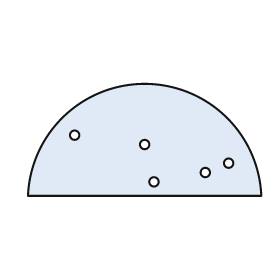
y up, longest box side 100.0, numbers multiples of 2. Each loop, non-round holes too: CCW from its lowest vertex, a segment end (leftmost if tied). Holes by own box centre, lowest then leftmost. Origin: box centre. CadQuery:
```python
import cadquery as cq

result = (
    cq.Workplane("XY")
    .moveTo(-50.0, -24.0)
    .lineTo(50.0, -24.0)
    .threePointArc((0.0, 24.0), (-50.0, -24.0))
    .close()
    .moveTo(4.0, -18.0)
    .circle(2.0)
    .moveTo(26.0, -14.0)
    .circle(2.0)
    .moveTo(36.0, -10.0)
    .circle(2.0)
    .moveTo(0.0, -2.0)
    .circle(2.0)
    .moveTo(-30.0, 2.0)
    .circle(2.0)
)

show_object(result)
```